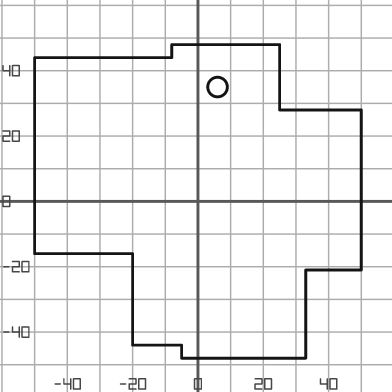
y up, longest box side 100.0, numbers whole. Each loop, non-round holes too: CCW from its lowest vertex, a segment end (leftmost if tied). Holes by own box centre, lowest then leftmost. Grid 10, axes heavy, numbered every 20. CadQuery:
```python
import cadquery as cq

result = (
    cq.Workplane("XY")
    .moveTo(-5.0, -48.0)
    .lineTo(33.0, -48.0)
    .lineTo(33.0, -21.0)
    .lineTo(50.0, -21.0)
    .lineTo(50.0, 28.0)
    .lineTo(25.0, 28.0)
    .lineTo(25.0, 48.0)
    .lineTo(-8.0, 48.0)
    .lineTo(-8.0, 44.0)
    .lineTo(-50.0, 44.0)
    .lineTo(-50.0, -16.0)
    .lineTo(-20.0, -16.0)
    .lineTo(-20.0, -44.0)
    .lineTo(-5.0, -44.0)
    .close()
    .moveTo(6.0, 35.0)
    .circle(3.0)
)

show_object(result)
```